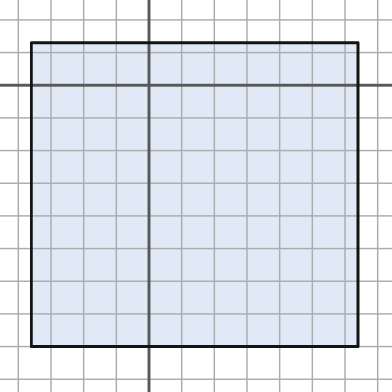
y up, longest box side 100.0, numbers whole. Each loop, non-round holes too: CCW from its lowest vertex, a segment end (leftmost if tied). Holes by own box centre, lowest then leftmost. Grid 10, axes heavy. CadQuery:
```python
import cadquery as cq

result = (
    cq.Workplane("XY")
    .moveTo(-36.0, -80.0)
    .lineTo(64.0, -80.0)
    .lineTo(64.0, 13.0)
    .lineTo(-36.0, 13.0)
    .close()
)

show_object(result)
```